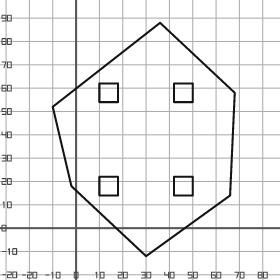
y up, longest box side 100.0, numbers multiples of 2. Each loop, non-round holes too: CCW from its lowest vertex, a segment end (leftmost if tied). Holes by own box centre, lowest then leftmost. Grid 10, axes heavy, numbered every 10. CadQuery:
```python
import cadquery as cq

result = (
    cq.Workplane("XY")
    .moveTo(30.0, -12.0)
    .lineTo(66.0, 14.0)
    .lineTo(68.0, 58.0)
    .lineTo(36.0, 88.0)
    .lineTo(-10.0, 52.0)
    .lineTo(-2.0, 18.0)
    .close()
    .moveTo(10.0, 14.0)
    .lineTo(18.0, 14.0)
    .lineTo(18.0, 22.0)
    .lineTo(10.0, 22.0)
    .close()
    .moveTo(42.0, 14.0)
    .lineTo(50.0, 14.0)
    .lineTo(50.0, 22.0)
    .lineTo(42.0, 22.0)
    .close()
    .moveTo(10.0, 54.0)
    .lineTo(18.0, 54.0)
    .lineTo(18.0, 62.0)
    .lineTo(10.0, 62.0)
    .close()
    .moveTo(42.0, 54.0)
    .lineTo(50.0, 54.0)
    .lineTo(50.0, 62.0)
    .lineTo(42.0, 62.0)
    .close()
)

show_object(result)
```